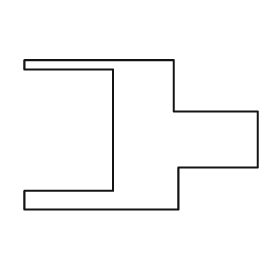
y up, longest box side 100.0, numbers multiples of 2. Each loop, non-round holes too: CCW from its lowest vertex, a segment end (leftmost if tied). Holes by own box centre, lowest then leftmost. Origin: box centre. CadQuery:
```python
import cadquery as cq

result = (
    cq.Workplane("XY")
    .moveTo(-50.0, -32.0)
    .lineTo(16.0, -32.0)
    .lineTo(16.0, -14.0)
    .lineTo(50.0, -14.0)
    .lineTo(50.0, 10.0)
    .lineTo(14.0, 10.0)
    .lineTo(14.0, 32.0)
    .lineTo(-50.0, 32.0)
    .lineTo(-50.0, 28.0)
    .lineTo(-12.0, 28.0)
    .lineTo(-12.0, -24.0)
    .lineTo(-50.0, -24.0)
    .close()
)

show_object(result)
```